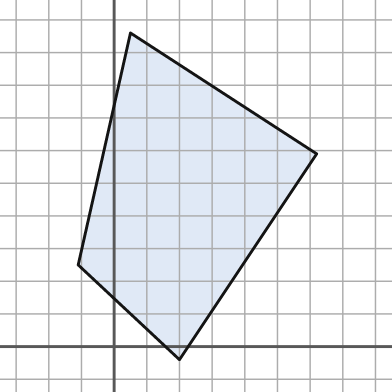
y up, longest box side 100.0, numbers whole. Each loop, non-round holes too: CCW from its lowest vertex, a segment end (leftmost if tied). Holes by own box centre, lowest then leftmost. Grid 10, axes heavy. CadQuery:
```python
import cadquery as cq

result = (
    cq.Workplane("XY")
    .moveTo(20.0, -4.0)
    .lineTo(62.0, 59.0)
    .lineTo(5.0, 96.0)
    .lineTo(-11.0, 25.0)
    .close()
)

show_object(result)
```